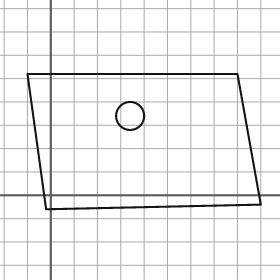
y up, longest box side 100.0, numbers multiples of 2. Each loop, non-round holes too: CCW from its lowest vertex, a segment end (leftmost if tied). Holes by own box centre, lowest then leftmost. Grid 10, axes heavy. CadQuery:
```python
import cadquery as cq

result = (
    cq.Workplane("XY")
    .moveTo(-2.0, -6.0)
    .lineTo(90.0, -4.0)
    .lineTo(80.0, 52.0)
    .lineTo(-10.0, 52.0)
    .close()
    .moveTo(34.0, 34.0)
    .circle(6.0)
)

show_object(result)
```